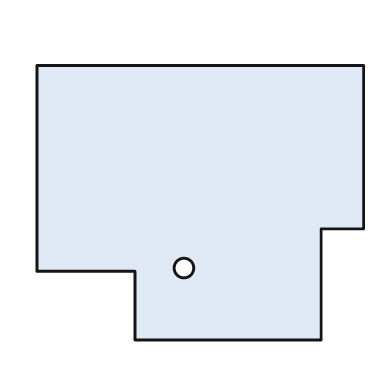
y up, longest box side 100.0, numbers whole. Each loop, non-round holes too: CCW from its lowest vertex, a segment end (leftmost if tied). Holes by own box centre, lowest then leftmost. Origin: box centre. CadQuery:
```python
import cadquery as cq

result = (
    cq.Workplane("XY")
    .moveTo(-20.0, -42.0)
    .lineTo(37.0, -42.0)
    .lineTo(37.0, -8.0)
    .lineTo(50.0, -8.0)
    .lineTo(50.0, 42.0)
    .lineTo(-50.0, 42.0)
    .lineTo(-50.0, -21.0)
    .lineTo(-20.0, -21.0)
    .close()
    .moveTo(-5.0, -20.0)
    .circle(3.0)
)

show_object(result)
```